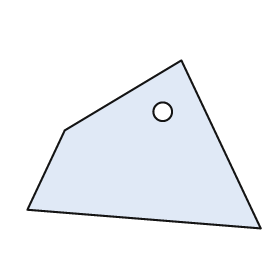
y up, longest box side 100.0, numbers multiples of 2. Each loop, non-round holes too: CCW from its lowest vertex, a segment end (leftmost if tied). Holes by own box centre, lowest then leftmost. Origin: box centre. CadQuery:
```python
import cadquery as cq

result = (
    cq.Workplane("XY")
    .moveTo(50.0, -36.0)
    .lineTo(16.0, 36.0)
    .lineTo(-34.0, 6.0)
    .lineTo(-50.0, -28.0)
    .close()
    .moveTo(8.0, 14.0)
    .circle(4.0)
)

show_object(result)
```